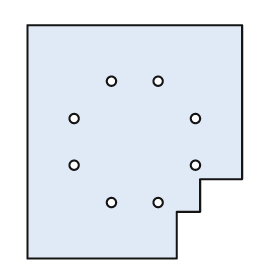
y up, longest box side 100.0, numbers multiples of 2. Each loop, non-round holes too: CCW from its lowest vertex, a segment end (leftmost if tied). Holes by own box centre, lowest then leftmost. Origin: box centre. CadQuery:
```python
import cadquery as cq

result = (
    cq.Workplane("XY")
    .moveTo(-46.0, -50.0)
    .lineTo(18.0, -50.0)
    .lineTo(18.0, -30.0)
    .lineTo(28.0, -30.0)
    .lineTo(28.0, -16.0)
    .lineTo(46.0, -16.0)
    .lineTo(46.0, 50.0)
    .lineTo(-46.0, 50.0)
    .close()
    .moveTo(-10.0, -26.0)
    .circle(2.0)
    .moveTo(10.0, -26.0)
    .circle(2.0)
    .moveTo(-26.0, -10.0)
    .circle(2.0)
    .moveTo(26.0, -10.0)
    .circle(2.0)
    .moveTo(-26.0, 10.0)
    .circle(2.0)
    .moveTo(26.0, 10.0)
    .circle(2.0)
    .moveTo(-10.0, 26.0)
    .circle(2.0)
    .moveTo(10.0, 26.0)
    .circle(2.0)
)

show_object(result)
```